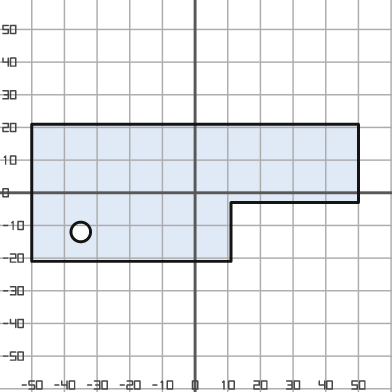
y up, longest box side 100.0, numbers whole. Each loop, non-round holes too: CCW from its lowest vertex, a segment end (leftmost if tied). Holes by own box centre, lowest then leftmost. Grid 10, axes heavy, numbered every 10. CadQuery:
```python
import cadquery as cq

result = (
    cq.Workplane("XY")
    .moveTo(-50.0, -21.0)
    .lineTo(11.0, -21.0)
    .lineTo(11.0, -3.0)
    .lineTo(50.0, -3.0)
    .lineTo(50.0, 21.0)
    .lineTo(-50.0, 21.0)
    .close()
    .moveTo(-35.0, -12.0)
    .circle(3.0)
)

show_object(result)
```